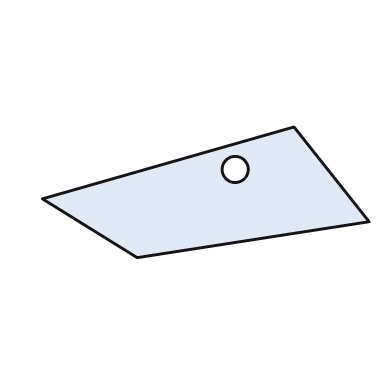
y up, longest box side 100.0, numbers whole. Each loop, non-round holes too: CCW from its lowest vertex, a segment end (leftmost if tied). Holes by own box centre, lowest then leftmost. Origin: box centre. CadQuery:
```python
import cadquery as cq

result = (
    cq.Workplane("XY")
    .moveTo(-21.0, -20.0)
    .lineTo(50.0, -9.0)
    .lineTo(27.0, 20.0)
    .lineTo(-50.0, -2.0)
    .close()
    .moveTo(9.0, 7.0)
    .circle(4.0)
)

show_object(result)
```